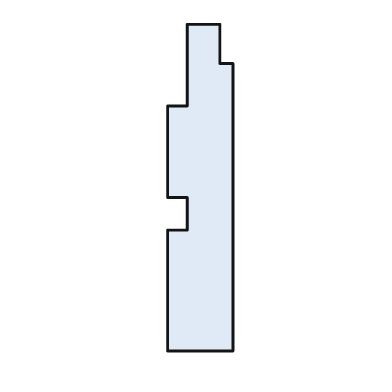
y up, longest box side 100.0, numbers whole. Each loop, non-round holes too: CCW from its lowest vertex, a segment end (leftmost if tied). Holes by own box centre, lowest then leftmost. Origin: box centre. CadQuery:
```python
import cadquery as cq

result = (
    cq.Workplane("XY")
    .moveTo(-10.0, -50.0)
    .lineTo(10.0, -50.0)
    .lineTo(10.0, 38.0)
    .lineTo(6.0, 38.0)
    .lineTo(6.0, 50.0)
    .lineTo(-4.0, 50.0)
    .lineTo(-4.0, 25.0)
    .lineTo(-10.0, 25.0)
    .lineTo(-10.0, -3.0)
    .lineTo(-4.0, -3.0)
    .lineTo(-4.0, -13.0)
    .lineTo(-10.0, -13.0)
    .close()
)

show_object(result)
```